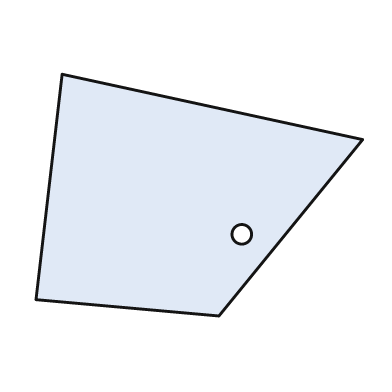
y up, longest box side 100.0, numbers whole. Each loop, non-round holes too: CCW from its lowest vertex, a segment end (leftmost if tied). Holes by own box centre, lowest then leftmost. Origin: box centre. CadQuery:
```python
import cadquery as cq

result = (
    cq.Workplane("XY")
    .moveTo(6.0, -37.0)
    .lineTo(50.0, 17.0)
    .lineTo(-42.0, 37.0)
    .lineTo(-50.0, -32.0)
    .close()
    .moveTo(13.0, -12.0)
    .circle(3.0)
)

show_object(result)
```